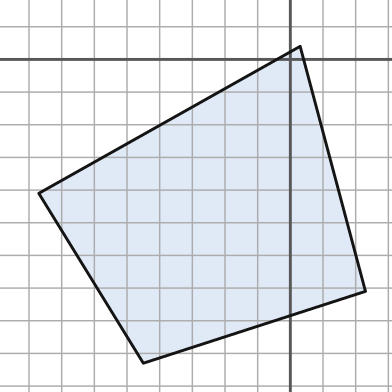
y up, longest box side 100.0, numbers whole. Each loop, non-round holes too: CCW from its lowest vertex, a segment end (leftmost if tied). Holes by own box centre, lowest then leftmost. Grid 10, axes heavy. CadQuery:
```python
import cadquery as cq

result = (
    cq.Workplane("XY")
    .moveTo(-45.0, -93.0)
    .lineTo(23.0, -71.0)
    .lineTo(3.0, 4.0)
    .lineTo(-77.0, -41.0)
    .close()
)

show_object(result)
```